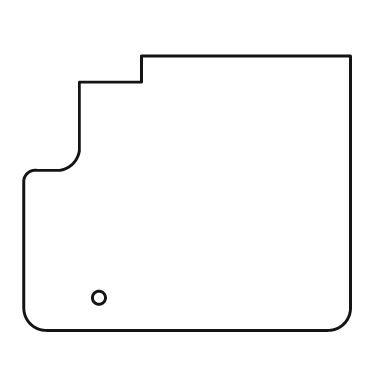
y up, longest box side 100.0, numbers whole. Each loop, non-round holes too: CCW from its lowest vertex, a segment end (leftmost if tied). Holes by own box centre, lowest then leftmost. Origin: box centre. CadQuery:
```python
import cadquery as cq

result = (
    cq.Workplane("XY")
    .moveTo(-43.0, -42.0)
    .lineTo(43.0, -42.0)
    .threePointArc((48.0, -40.0), (50.0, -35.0))
    .lineTo(50.0, 42.0)
    .lineTo(-14.0, 42.0)
    .lineTo(-14.0, 34.0)
    .lineTo(-33.0, 34.0)
    .lineTo(-33.0, 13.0)
    .threePointArc((-35.0, 9.0), (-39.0, 7.0))
    .lineTo(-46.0, 7.0)
    .threePointArc((-49.0, 6.0), (-50.0, 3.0))
    .lineTo(-50.0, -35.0)
    .threePointArc((-48.0, -40.0), (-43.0, -42.0))
    .close()
    .moveTo(-27.0, -32.0)
    .circle(2.0)
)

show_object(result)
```